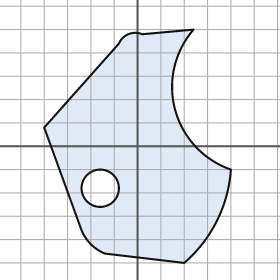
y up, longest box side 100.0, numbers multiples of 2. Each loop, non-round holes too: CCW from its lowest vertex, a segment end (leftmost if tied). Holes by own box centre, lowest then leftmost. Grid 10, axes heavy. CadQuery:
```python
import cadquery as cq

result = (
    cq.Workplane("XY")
    .moveTo(20.0, -50.0)
    .threePointArc((34.0, -32.0), (40.0, -10.0))
    .threePointArc((16.0, 16.0), (24.0, 50.0))
    .lineTo(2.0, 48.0)
    .threePointArc((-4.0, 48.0), (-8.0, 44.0))
    .lineTo(-40.0, 8.0)
    .lineTo(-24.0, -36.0)
    .threePointArc((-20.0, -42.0), (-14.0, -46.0))
    .close()
    .moveTo(-16.0, -18.0)
    .circle(8.0)
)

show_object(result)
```